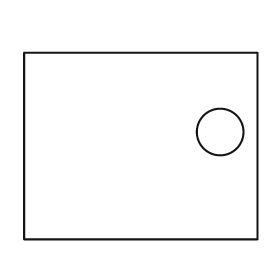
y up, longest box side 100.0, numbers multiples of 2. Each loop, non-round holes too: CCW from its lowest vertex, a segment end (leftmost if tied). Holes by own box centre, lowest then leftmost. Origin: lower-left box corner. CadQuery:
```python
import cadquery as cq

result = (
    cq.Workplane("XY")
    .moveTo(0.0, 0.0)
    .lineTo(100.0, 0.0)
    .lineTo(100.0, 80.0)
    .lineTo(0.0, 80.0)
    .close()
    .moveTo(84.0, 46.0)
    .circle(10.0)
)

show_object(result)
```